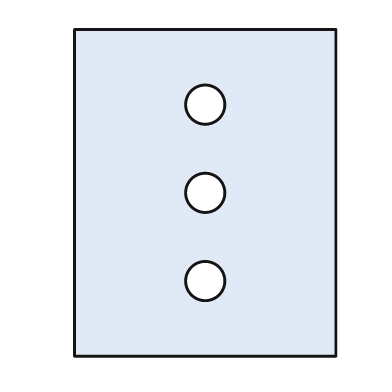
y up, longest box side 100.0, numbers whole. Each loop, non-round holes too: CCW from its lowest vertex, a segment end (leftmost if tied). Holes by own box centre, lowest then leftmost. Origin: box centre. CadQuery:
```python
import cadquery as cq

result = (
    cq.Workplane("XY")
    .moveTo(-40.0, -50.0)
    .lineTo(40.0, -50.0)
    .lineTo(40.0, 50.0)
    .lineTo(-40.0, 50.0)
    .close()
    .moveTo(0.0, -27.0)
    .circle(6.0)
    .moveTo(0.0, 0.0)
    .circle(6.0)
    .moveTo(0.0, 27.0)
    .circle(6.0)
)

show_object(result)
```